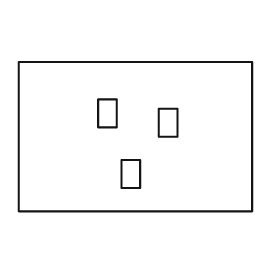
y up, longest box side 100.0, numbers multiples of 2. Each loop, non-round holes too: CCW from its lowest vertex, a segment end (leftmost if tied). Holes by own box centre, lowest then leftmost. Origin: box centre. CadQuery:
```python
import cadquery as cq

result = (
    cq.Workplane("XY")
    .moveTo(-50.0, -32.0)
    .lineTo(50.0, -32.0)
    .lineTo(50.0, 32.0)
    .lineTo(-50.0, 32.0)
    .close()
    .moveTo(-6.0, -22.0)
    .lineTo(2.0, -22.0)
    .lineTo(2.0, -10.0)
    .lineTo(-6.0, -10.0)
    .close()
    .moveTo(10.0, 0.0)
    .lineTo(18.0, 0.0)
    .lineTo(18.0, 12.0)
    .lineTo(10.0, 12.0)
    .close()
    .moveTo(-16.0, 4.0)
    .lineTo(-8.0, 4.0)
    .lineTo(-8.0, 16.0)
    .lineTo(-16.0, 16.0)
    .close()
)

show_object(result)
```